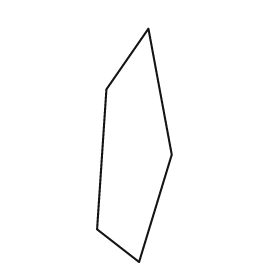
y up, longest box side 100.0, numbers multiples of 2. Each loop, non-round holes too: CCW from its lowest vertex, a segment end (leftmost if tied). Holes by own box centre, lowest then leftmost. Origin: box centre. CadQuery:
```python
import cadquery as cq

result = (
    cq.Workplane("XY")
    .moveTo(2.0, -50.0)
    .lineTo(16.0, -4.0)
    .lineTo(6.0, 50.0)
    .lineTo(-12.0, 24.0)
    .lineTo(-16.0, -36.0)
    .close()
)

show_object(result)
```